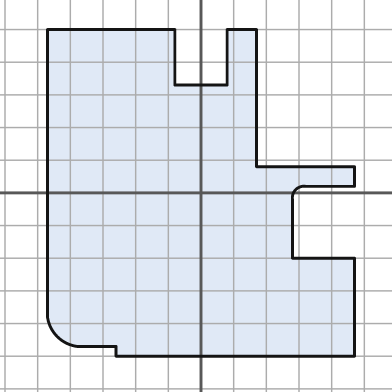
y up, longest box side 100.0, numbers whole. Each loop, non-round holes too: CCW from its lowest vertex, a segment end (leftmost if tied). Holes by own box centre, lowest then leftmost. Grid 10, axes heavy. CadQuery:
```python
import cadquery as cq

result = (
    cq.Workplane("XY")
    .moveTo(-26.0, -50.0)
    .lineTo(47.0, -50.0)
    .lineTo(47.0, -20.0)
    .lineTo(28.0, -20.0)
    .lineTo(28.0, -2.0)
    .threePointArc((29.0, 1.0), (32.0, 2.0))
    .lineTo(47.0, 2.0)
    .lineTo(47.0, 8.0)
    .lineTo(17.0, 8.0)
    .lineTo(17.0, 50.0)
    .lineTo(8.0, 50.0)
    .lineTo(8.0, 33.0)
    .lineTo(-8.0, 33.0)
    .lineTo(-8.0, 50.0)
    .lineTo(-47.0, 50.0)
    .lineTo(-47.0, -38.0)
    .threePointArc((-44.0, -44.0), (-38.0, -47.0))
    .lineTo(-26.0, -47.0)
    .close()
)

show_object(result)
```